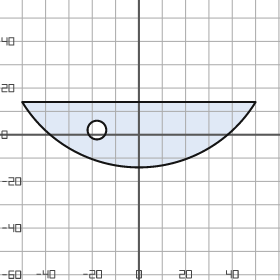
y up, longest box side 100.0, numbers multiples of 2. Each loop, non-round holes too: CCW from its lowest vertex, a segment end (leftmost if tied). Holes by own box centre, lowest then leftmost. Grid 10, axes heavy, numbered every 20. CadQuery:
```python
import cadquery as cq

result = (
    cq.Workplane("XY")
    .moveTo(-50.0, 14.0)
    .threePointArc((0.0, -14.0), (50.0, 14.0))
    .close()
    .moveTo(-18.0, 2.0)
    .circle(4.0)
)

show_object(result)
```